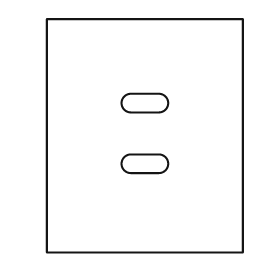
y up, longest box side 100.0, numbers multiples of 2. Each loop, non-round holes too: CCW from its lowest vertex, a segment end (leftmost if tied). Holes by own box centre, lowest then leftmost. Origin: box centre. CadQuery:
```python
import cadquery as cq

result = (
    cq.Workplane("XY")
    .moveTo(-42.0, -50.0)
    .lineTo(42.0, -50.0)
    .lineTo(42.0, 50.0)
    .lineTo(-42.0, 50.0)
    .close()
    .moveTo(-6.0, -16.0)
    .lineTo(6.0, -16.0)
    .threePointArc((10.0, -12.0), (6.0, -8.0))
    .lineTo(-6.0, -8.0)
    .threePointArc((-10.0, -12.0), (-6.0, -16.0))
    .close()
    .moveTo(-6.0, 10.0)
    .lineTo(6.0, 10.0)
    .threePointArc((10.0, 14.0), (6.0, 18.0))
    .lineTo(-6.0, 18.0)
    .threePointArc((-10.0, 14.0), (-6.0, 10.0))
    .close()
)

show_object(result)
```